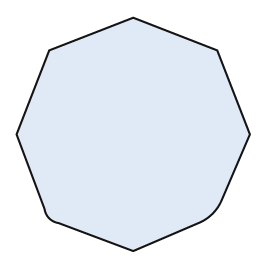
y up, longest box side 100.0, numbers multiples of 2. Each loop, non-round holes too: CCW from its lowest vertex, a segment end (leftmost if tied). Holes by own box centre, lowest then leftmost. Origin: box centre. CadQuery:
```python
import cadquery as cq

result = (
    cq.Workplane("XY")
    .moveTo(0.0, -50.0)
    .lineTo(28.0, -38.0)
    .threePointArc((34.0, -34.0), (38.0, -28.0))
    .lineTo(50.0, 0.0)
    .lineTo(36.0, 36.0)
    .lineTo(0.0, 50.0)
    .lineTo(-36.0, 36.0)
    .lineTo(-50.0, 0.0)
    .lineTo(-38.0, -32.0)
    .threePointArc((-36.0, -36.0), (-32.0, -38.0))
    .close()
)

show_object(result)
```